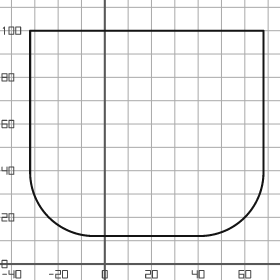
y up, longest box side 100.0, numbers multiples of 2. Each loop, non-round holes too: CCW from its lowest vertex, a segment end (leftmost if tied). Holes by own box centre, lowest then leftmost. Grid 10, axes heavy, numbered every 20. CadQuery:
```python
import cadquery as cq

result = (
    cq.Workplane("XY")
    .moveTo(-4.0, 12.0)
    .lineTo(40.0, 12.0)
    .threePointArc((60.0, 20.0), (68.0, 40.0))
    .lineTo(68.0, 100.0)
    .lineTo(-32.0, 100.0)
    .lineTo(-32.0, 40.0)
    .threePointArc((-24.0, 20.0), (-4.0, 12.0))
    .close()
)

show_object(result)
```